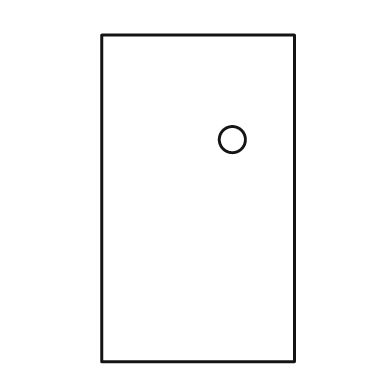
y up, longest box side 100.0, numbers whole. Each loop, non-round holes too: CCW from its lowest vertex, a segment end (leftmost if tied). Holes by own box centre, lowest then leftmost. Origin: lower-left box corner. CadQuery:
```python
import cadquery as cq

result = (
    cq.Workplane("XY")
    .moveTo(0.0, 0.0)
    .lineTo(59.0, 0.0)
    .lineTo(59.0, 100.0)
    .lineTo(0.0, 100.0)
    .close()
    .moveTo(40.0, 68.0)
    .circle(4.0)
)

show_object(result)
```